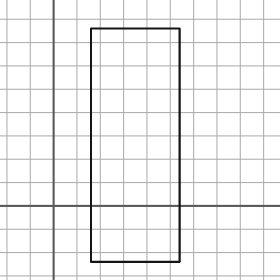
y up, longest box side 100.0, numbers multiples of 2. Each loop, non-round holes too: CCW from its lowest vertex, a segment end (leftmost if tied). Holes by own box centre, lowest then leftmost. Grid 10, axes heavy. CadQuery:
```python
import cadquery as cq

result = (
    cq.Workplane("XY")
    .moveTo(16.0, -24.0)
    .lineTo(54.0, -24.0)
    .lineTo(54.0, 76.0)
    .lineTo(16.0, 76.0)
    .close()
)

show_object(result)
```